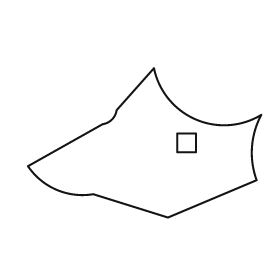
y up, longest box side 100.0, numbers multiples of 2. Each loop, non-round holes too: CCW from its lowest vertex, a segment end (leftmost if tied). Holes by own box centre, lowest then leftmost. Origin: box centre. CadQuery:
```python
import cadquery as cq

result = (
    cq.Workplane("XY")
    .moveTo(10.0, -32.0)
    .lineTo(48.0, -16.0)
    .threePointArc((46.0, -2.0), (50.0, 12.0))
    .threePointArc((22.0, 10.0), (4.0, 32.0))
    .lineTo(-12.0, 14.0)
    .threePointArc((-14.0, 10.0), (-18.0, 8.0))
    .lineTo(-50.0, -10.0)
    .threePointArc((-38.0, -20.0), (-22.0, -22.0))
    .close()
    .moveTo(14.0, -4.0)
    .lineTo(22.0, -4.0)
    .lineTo(22.0, 4.0)
    .lineTo(14.0, 4.0)
    .close()
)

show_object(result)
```